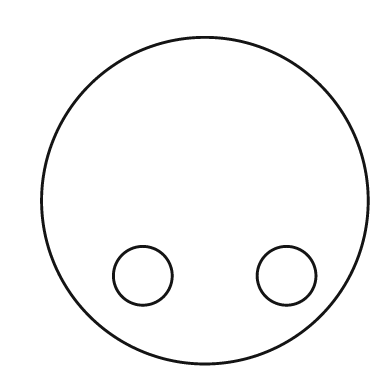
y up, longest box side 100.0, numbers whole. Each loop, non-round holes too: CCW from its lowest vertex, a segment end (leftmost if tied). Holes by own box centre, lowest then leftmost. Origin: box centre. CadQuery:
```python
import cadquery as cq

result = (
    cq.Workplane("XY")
    .moveTo(0.0, 0.0)
    .circle(50.0)
    .moveTo(-19.0, -23.0)
    .circle(9.0)
    .moveTo(25.0, -23.0)
    .circle(9.0)
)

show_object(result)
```